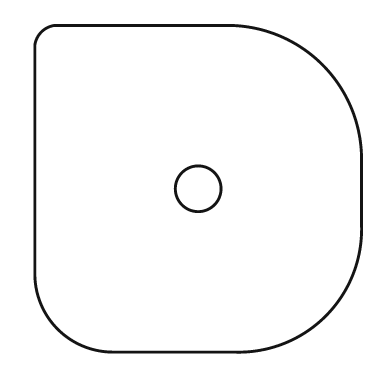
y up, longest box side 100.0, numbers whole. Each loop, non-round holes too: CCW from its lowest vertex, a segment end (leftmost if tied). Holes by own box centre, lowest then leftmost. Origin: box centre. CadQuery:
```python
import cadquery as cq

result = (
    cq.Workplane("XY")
    .moveTo(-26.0, -50.0)
    .lineTo(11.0, -50.0)
    .threePointArc((39.0, -39.0), (50.0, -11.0))
    .lineTo(50.0, 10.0)
    .threePointArc((38.0, 38.0), (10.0, 50.0))
    .lineTo(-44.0, 50.0)
    .threePointArc((-48.0, 48.0), (-50.0, 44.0))
    .lineTo(-50.0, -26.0)
    .threePointArc((-43.0, -43.0), (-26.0, -50.0))
    .close()
    .moveTo(0.0, 0.0)
    .circle(7.0)
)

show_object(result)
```